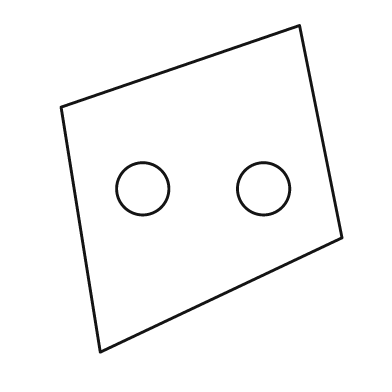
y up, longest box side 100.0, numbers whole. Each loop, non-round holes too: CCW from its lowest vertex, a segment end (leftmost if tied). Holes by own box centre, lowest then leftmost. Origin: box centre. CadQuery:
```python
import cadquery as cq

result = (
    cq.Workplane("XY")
    .moveTo(-31.0, -50.0)
    .lineTo(43.0, -15.0)
    .lineTo(30.0, 50.0)
    .lineTo(-43.0, 25.0)
    .close()
    .moveTo(-18.0, 0.0)
    .circle(8.0)
    .moveTo(19.0, 0.0)
    .circle(8.0)
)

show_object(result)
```